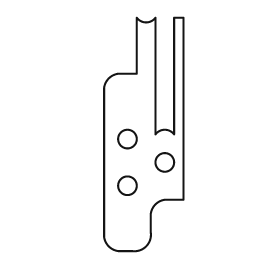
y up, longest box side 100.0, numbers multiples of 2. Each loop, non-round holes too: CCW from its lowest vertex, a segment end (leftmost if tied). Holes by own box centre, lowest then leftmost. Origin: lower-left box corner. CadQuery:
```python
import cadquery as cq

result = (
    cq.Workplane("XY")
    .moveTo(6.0, 0.0)
    .lineTo(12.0, 0.0)
    .threePointArc((18.0, 2.0), (20.0, 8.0))
    .lineTo(20.0, 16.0)
    .threePointArc((22.0, 20.0), (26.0, 22.0))
    .lineTo(34.0, 22.0)
    .lineTo(34.0, 100.0)
    .lineTo(30.0, 100.0)
    .lineTo(30.0, 50.0)
    .threePointArc((26.0, 52.0), (22.0, 50.0))
    .lineTo(22.0, 100.0)
    .threePointArc((18.0, 98.0), (14.0, 100.0))
    .lineTo(14.0, 76.0)
    .lineTo(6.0, 76.0)
    .threePointArc((2.0, 74.0), (0.0, 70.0))
    .lineTo(0.0, 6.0)
    .threePointArc((2.0, 2.0), (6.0, 0.0))
    .close()
    .moveTo(10.0, 28.0)
    .circle(4.0)
    .moveTo(26.0, 38.0)
    .circle(4.0)
    .moveTo(10.0, 48.0)
    .circle(4.0)
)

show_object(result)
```